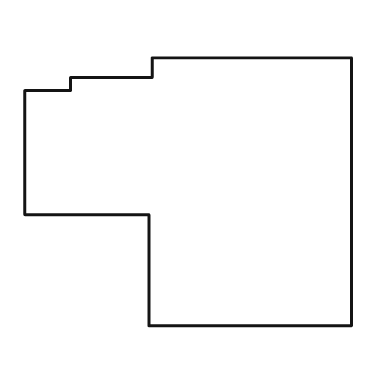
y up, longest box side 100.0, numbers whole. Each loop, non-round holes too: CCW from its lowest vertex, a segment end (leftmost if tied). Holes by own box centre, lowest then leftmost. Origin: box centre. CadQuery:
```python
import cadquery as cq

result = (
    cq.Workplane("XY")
    .moveTo(-12.0, -41.0)
    .lineTo(50.0, -41.0)
    .lineTo(50.0, 41.0)
    .lineTo(-11.0, 41.0)
    .lineTo(-11.0, 35.0)
    .lineTo(-36.0, 35.0)
    .lineTo(-36.0, 31.0)
    .lineTo(-50.0, 31.0)
    .lineTo(-50.0, -7.0)
    .lineTo(-12.0, -7.0)
    .close()
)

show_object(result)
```